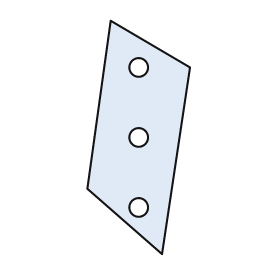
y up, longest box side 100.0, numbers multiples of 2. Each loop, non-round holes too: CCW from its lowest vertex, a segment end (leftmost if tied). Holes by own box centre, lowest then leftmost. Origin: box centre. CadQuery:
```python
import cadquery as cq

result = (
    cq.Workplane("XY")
    .moveTo(10.0, -50.0)
    .lineTo(22.0, 30.0)
    .lineTo(-12.0, 50.0)
    .lineTo(-22.0, -22.0)
    .close()
    .moveTo(0.0, -30.0)
    .circle(4.0)
    .moveTo(0.0, 0.0)
    .circle(4.0)
    .moveTo(0.0, 30.0)
    .circle(4.0)
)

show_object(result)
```